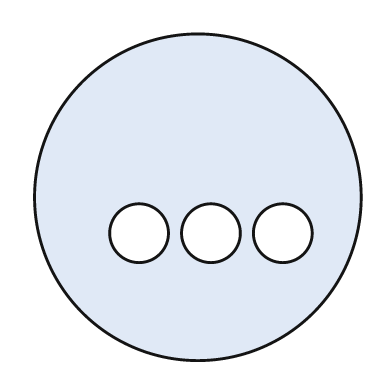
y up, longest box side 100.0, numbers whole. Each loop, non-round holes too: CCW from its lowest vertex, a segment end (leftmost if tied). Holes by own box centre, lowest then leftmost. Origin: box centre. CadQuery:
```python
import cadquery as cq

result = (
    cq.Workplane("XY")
    .moveTo(0.0, 0.0)
    .circle(50.0)
    .moveTo(-18.0, -11.0)
    .circle(9.0)
    .moveTo(4.0, -11.0)
    .circle(9.0)
    .moveTo(26.0, -11.0)
    .circle(9.0)
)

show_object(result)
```